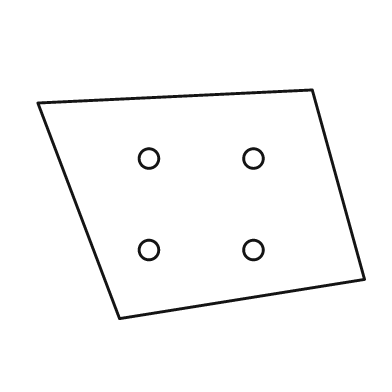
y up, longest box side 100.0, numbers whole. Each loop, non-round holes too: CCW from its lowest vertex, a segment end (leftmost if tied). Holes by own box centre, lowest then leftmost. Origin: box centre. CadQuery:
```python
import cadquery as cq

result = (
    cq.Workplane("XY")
    .moveTo(-25.0, -35.0)
    .lineTo(50.0, -23.0)
    .lineTo(34.0, 35.0)
    .lineTo(-50.0, 31.0)
    .close()
    .moveTo(-16.0, -14.0)
    .circle(3.0)
    .moveTo(16.0, -14.0)
    .circle(3.0)
    .moveTo(-16.0, 14.0)
    .circle(3.0)
    .moveTo(16.0, 14.0)
    .circle(3.0)
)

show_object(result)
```